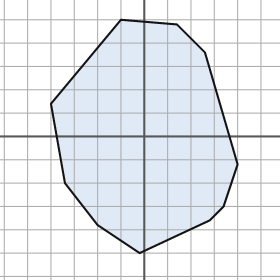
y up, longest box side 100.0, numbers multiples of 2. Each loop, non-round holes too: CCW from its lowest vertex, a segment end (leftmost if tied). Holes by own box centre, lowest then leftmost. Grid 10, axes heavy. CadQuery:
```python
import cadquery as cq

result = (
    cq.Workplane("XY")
    .moveTo(-2.0, -50.0)
    .lineTo(28.0, -36.0)
    .lineTo(34.0, -30.0)
    .lineTo(40.0, -12.0)
    .lineTo(26.0, 36.0)
    .lineTo(14.0, 48.0)
    .lineTo(-10.0, 50.0)
    .lineTo(-40.0, 14.0)
    .lineTo(-34.0, -20.0)
    .lineTo(-20.0, -38.0)
    .close()
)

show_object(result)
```